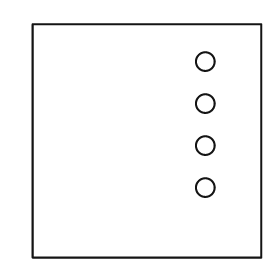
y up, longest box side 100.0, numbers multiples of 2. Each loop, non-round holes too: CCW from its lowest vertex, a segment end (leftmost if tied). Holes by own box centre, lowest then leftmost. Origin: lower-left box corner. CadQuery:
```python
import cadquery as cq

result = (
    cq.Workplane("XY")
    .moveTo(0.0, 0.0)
    .lineTo(98.0, 0.0)
    .lineTo(98.0, 100.0)
    .lineTo(0.0, 100.0)
    .close()
    .moveTo(74.0, 30.0)
    .circle(4.0)
    .moveTo(74.0, 48.0)
    .circle(4.0)
    .moveTo(74.0, 66.0)
    .circle(4.0)
    .moveTo(74.0, 84.0)
    .circle(4.0)
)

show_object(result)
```